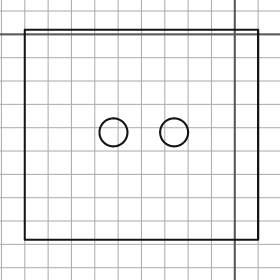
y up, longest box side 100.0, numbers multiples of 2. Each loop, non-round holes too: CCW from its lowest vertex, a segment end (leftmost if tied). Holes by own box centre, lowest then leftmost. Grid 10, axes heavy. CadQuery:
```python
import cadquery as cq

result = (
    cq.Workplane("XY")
    .moveTo(-90.0, -88.0)
    .lineTo(10.0, -88.0)
    .lineTo(10.0, 2.0)
    .lineTo(-90.0, 2.0)
    .close()
    .moveTo(-52.0, -42.0)
    .circle(6.0)
    .moveTo(-26.0, -42.0)
    .circle(6.0)
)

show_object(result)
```